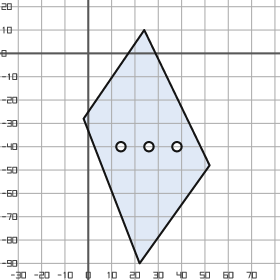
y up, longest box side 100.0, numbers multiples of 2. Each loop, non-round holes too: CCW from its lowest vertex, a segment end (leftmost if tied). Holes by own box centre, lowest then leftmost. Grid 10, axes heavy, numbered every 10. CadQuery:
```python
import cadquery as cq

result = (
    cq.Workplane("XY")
    .moveTo(22.0, -90.0)
    .lineTo(52.0, -48.0)
    .lineTo(24.0, 10.0)
    .lineTo(-2.0, -28.0)
    .close()
    .moveTo(14.0, -40.0)
    .circle(2.0)
    .moveTo(26.0, -40.0)
    .circle(2.0)
    .moveTo(38.0, -40.0)
    .circle(2.0)
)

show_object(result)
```